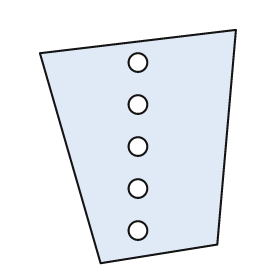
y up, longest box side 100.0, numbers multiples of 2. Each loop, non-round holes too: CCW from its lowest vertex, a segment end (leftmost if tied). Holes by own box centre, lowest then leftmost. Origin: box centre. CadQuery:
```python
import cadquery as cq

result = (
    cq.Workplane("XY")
    .moveTo(-16.0, -50.0)
    .lineTo(34.0, -42.0)
    .lineTo(42.0, 50.0)
    .lineTo(-42.0, 40.0)
    .close()
    .moveTo(0.0, -36.0)
    .circle(4.0)
    .moveTo(0.0, -18.0)
    .circle(4.0)
    .moveTo(0.0, 0.0)
    .circle(4.0)
    .moveTo(0.0, 18.0)
    .circle(4.0)
    .moveTo(0.0, 36.0)
    .circle(4.0)
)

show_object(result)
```